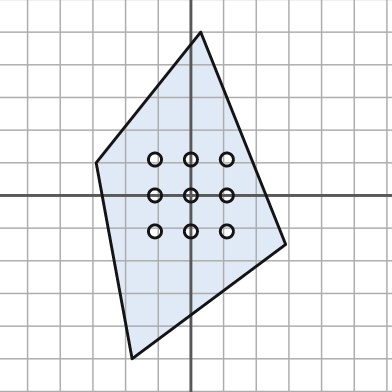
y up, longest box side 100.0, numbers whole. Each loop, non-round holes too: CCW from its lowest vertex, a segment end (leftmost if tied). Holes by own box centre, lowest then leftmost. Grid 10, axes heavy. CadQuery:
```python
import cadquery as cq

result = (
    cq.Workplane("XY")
    .moveTo(-18.0, -50.0)
    .lineTo(29.0, -15.0)
    .lineTo(3.0, 50.0)
    .lineTo(-29.0, 10.0)
    .close()
    .moveTo(-11.0, -11.0)
    .circle(2.0)
    .moveTo(0.0, -11.0)
    .circle(2.0)
    .moveTo(11.0, -11.0)
    .circle(2.0)
    .moveTo(-11.0, 0.0)
    .circle(2.0)
    .moveTo(0.0, 0.0)
    .circle(2.0)
    .moveTo(11.0, 0.0)
    .circle(2.0)
    .moveTo(-11.0, 11.0)
    .circle(2.0)
    .moveTo(0.0, 11.0)
    .circle(2.0)
    .moveTo(11.0, 11.0)
    .circle(2.0)
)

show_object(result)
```